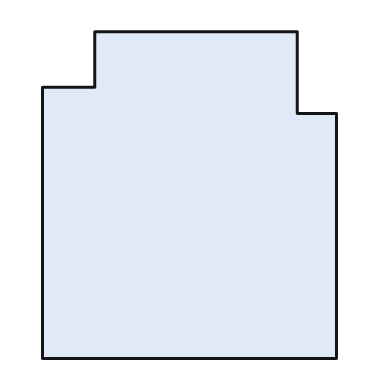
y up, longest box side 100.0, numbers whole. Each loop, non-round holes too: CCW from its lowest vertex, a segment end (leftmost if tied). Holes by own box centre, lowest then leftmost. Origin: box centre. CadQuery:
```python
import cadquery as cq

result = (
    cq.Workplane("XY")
    .moveTo(-45.0, -50.0)
    .lineTo(45.0, -50.0)
    .lineTo(45.0, 25.0)
    .lineTo(33.0, 25.0)
    .lineTo(33.0, 50.0)
    .lineTo(-29.0, 50.0)
    .lineTo(-29.0, 33.0)
    .lineTo(-45.0, 33.0)
    .close()
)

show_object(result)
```